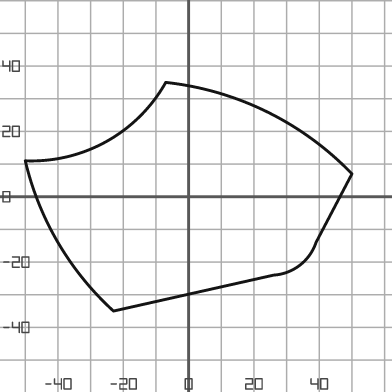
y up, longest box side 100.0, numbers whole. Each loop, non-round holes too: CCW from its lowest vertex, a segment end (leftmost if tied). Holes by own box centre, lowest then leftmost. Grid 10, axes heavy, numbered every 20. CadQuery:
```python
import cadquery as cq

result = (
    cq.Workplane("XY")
    .moveTo(-23.0, -35.0)
    .lineTo(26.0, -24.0)
    .threePointArc((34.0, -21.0), (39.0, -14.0))
    .lineTo(50.0, 7.0)
    .threePointArc((24.0, 26.0), (-7.0, 35.0))
    .threePointArc((-25.0, 17.0), (-50.0, 11.0))
    .threePointArc((-40.0, -14.0), (-23.0, -35.0))
    .close()
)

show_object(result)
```